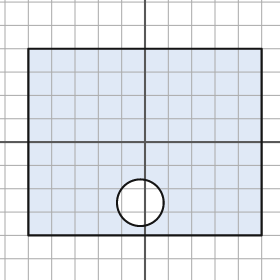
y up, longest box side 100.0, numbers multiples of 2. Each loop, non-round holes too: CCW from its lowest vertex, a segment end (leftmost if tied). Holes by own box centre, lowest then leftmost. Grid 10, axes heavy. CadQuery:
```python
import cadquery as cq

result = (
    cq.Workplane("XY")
    .moveTo(-50.0, -40.0)
    .lineTo(50.0, -40.0)
    .lineTo(50.0, 40.0)
    .lineTo(-50.0, 40.0)
    .close()
    .moveTo(-2.0, -26.0)
    .circle(10.0)
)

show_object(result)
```